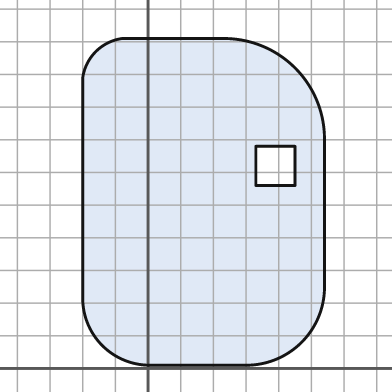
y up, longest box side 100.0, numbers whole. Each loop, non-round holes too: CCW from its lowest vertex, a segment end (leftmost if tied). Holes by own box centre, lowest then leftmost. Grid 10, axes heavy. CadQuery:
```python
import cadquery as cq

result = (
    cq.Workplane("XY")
    .moveTo(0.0, 1.0)
    .lineTo(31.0, 1.0)
    .threePointArc((47.0, 8.0), (54.0, 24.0))
    .lineTo(54.0, 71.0)
    .threePointArc((45.0, 92.0), (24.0, 101.0))
    .lineTo(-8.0, 101.0)
    .threePointArc((-16.0, 97.0), (-20.0, 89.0))
    .lineTo(-20.0, 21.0)
    .threePointArc((-14.0, 7.0), (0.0, 1.0))
    .close()
    .moveTo(33.0, 56.0)
    .lineTo(45.0, 56.0)
    .lineTo(45.0, 68.0)
    .lineTo(33.0, 68.0)
    .close()
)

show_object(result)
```